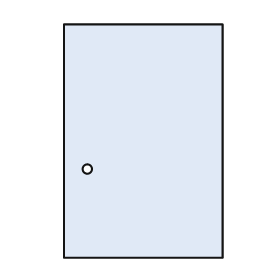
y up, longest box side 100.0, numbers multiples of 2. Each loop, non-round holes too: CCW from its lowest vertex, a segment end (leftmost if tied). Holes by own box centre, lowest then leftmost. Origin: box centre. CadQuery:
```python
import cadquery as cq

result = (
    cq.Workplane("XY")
    .moveTo(-34.0, -50.0)
    .lineTo(34.0, -50.0)
    .lineTo(34.0, 50.0)
    .lineTo(-34.0, 50.0)
    .close()
    .moveTo(-24.0, -12.0)
    .circle(2.0)
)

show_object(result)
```